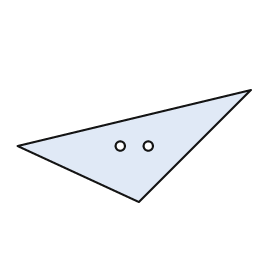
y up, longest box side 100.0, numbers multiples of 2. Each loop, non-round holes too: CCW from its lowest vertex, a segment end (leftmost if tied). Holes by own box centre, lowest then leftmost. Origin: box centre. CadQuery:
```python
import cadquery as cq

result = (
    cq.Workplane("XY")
    .moveTo(2.0, -24.0)
    .lineTo(50.0, 24.0)
    .lineTo(-50.0, 0.0)
    .close()
    .moveTo(-6.0, 0.0)
    .circle(2.0)
    .moveTo(6.0, 0.0)
    .circle(2.0)
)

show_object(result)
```